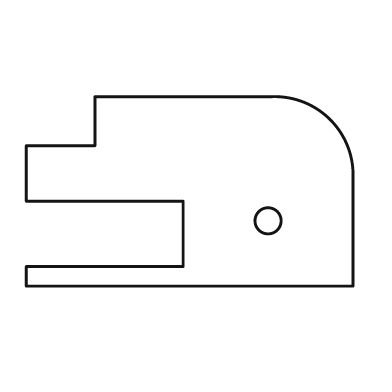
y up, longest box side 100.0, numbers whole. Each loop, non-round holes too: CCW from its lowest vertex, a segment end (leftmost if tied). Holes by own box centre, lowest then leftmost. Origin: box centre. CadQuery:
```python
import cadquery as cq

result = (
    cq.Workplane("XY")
    .moveTo(-50.0, -29.0)
    .lineTo(50.0, -29.0)
    .lineTo(50.0, 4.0)
    .threePointArc((43.0, 22.0), (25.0, 29.0))
    .lineTo(-29.0, 29.0)
    .lineTo(-29.0, 14.0)
    .lineTo(-50.0, 14.0)
    .lineTo(-50.0, -3.0)
    .lineTo(-2.0, -3.0)
    .lineTo(-2.0, -23.0)
    .lineTo(-50.0, -23.0)
    .close()
    .moveTo(24.0, -9.0)
    .circle(4.0)
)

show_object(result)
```